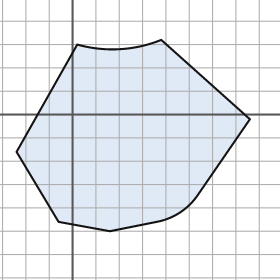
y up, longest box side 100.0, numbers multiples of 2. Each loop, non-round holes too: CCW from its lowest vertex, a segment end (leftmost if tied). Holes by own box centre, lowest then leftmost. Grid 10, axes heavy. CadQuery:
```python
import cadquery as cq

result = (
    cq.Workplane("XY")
    .moveTo(16.0, -50.0)
    .lineTo(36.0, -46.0)
    .threePointArc((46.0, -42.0), (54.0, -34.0))
    .lineTo(76.0, -2.0)
    .lineTo(38.0, 32.0)
    .threePointArc((20.0, 28.0), (2.0, 30.0))
    .lineTo(-24.0, -16.0)
    .lineTo(-6.0, -46.0)
    .close()
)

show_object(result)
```